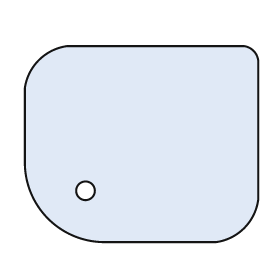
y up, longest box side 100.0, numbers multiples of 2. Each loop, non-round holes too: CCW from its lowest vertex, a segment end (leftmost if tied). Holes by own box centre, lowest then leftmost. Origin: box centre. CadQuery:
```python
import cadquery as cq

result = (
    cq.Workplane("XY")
    .moveTo(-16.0, -42.0)
    .lineTo(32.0, -42.0)
    .threePointArc((44.0, -36.0), (50.0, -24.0))
    .lineTo(50.0, 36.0)
    .threePointArc((48.0, 40.0), (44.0, 42.0))
    .lineTo(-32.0, 42.0)
    .threePointArc((-44.0, 36.0), (-50.0, 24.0))
    .lineTo(-50.0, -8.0)
    .threePointArc((-40.0, -32.0), (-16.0, -42.0))
    .close()
    .moveTo(-24.0, -20.0)
    .circle(4.0)
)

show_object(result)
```